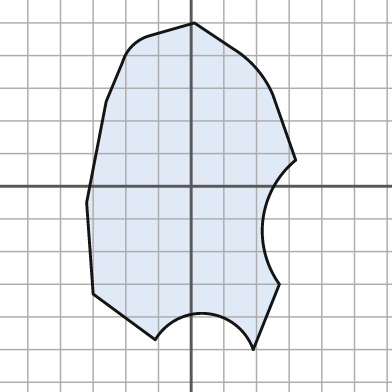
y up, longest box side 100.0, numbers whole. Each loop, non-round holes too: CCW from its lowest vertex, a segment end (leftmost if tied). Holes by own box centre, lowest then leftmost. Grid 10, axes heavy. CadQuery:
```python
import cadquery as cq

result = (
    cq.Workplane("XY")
    .moveTo(19.0, -50.0)
    .lineTo(27.0, -30.0)
    .threePointArc((22.0, -10.0), (32.0, 8.0))
    .lineTo(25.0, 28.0)
    .threePointArc((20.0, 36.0), (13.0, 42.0))
    .lineTo(1.0, 50.0)
    .lineTo(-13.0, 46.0)
    .threePointArc((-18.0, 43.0), (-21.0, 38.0))
    .lineTo(-26.0, 26.0)
    .lineTo(-32.0, -5.0)
    .lineTo(-30.0, -33.0)
    .lineTo(-11.0, -47.0)
    .threePointArc((5.0, -39.0), (19.0, -50.0))
    .close()
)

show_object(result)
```